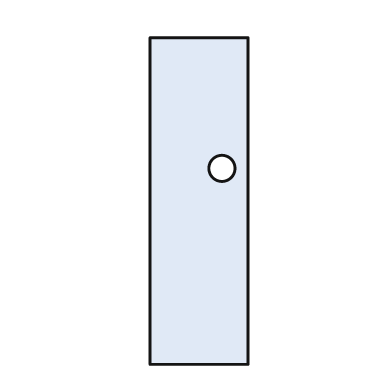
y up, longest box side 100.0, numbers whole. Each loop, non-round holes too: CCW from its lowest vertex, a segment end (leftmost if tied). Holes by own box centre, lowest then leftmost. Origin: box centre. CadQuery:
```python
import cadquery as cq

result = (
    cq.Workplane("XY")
    .moveTo(-15.0, -50.0)
    .lineTo(15.0, -50.0)
    .lineTo(15.0, 50.0)
    .lineTo(-15.0, 50.0)
    .close()
    .moveTo(7.0, 10.0)
    .circle(4.0)
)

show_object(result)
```